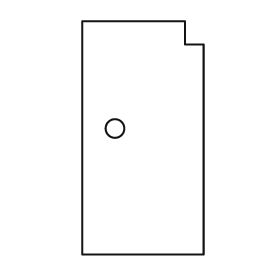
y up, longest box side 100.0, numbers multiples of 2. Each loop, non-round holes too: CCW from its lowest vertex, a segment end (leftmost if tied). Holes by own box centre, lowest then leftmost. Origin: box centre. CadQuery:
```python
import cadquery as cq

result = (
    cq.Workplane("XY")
    .moveTo(-26.0, -50.0)
    .lineTo(26.0, -50.0)
    .lineTo(26.0, 40.0)
    .lineTo(18.0, 40.0)
    .lineTo(18.0, 50.0)
    .lineTo(-26.0, 50.0)
    .close()
    .moveTo(-12.0, 4.0)
    .circle(4.0)
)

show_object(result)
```